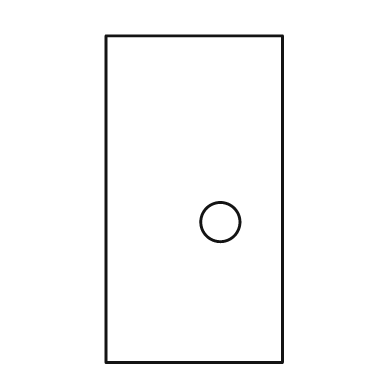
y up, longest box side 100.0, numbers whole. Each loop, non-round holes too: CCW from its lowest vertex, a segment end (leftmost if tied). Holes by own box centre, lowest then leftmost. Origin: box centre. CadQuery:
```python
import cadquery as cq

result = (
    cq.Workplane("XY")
    .moveTo(-27.0, -50.0)
    .lineTo(27.0, -50.0)
    .lineTo(27.0, 50.0)
    .lineTo(-27.0, 50.0)
    .close()
    .moveTo(8.0, -7.0)
    .circle(6.0)
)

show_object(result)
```